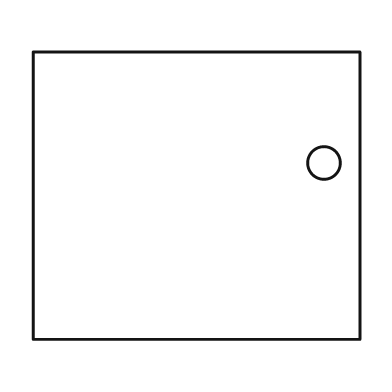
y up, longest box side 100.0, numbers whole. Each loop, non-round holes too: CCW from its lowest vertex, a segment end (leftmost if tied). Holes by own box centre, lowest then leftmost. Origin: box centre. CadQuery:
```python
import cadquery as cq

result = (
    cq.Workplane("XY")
    .moveTo(-50.0, -44.0)
    .lineTo(50.0, -44.0)
    .lineTo(50.0, 44.0)
    .lineTo(-50.0, 44.0)
    .close()
    .moveTo(39.0, 10.0)
    .circle(5.0)
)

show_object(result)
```